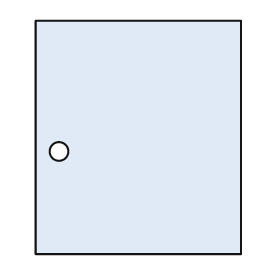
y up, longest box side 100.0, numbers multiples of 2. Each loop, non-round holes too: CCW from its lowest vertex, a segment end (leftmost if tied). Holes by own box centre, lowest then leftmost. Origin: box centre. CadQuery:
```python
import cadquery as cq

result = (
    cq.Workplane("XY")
    .moveTo(-44.0, -50.0)
    .lineTo(44.0, -50.0)
    .lineTo(44.0, 50.0)
    .lineTo(-44.0, 50.0)
    .close()
    .moveTo(-34.0, -6.0)
    .circle(4.0)
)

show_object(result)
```